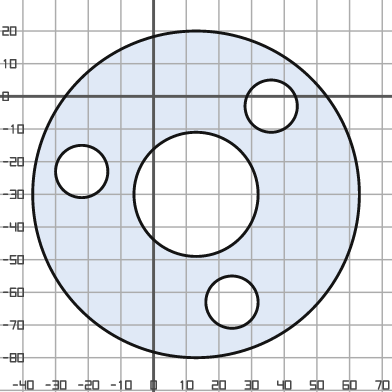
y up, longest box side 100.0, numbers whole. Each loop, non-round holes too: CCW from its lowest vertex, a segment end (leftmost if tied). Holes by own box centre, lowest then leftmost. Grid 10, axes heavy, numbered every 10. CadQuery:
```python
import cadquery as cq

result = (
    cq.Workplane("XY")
    .moveTo(13.0, -30.0)
    .circle(50.0)
    .moveTo(24.0, -63.0)
    .circle(8.0)
    .moveTo(13.0, -30.0)
    .circle(19.0)
    .moveTo(-22.0, -23.0)
    .circle(8.0)
    .moveTo(36.0, -3.0)
    .circle(8.0)
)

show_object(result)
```